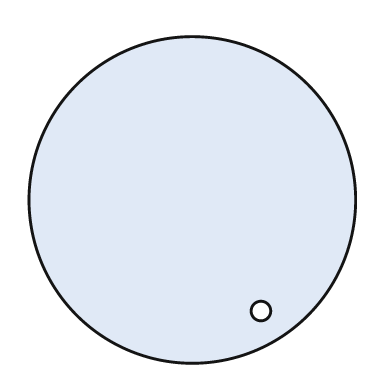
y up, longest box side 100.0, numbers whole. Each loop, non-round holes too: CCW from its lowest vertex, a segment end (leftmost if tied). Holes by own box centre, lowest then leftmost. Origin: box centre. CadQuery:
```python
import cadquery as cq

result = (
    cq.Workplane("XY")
    .moveTo(0.0, 0.0)
    .circle(50.0)
    .moveTo(21.0, -34.0)
    .circle(3.0)
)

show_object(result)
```